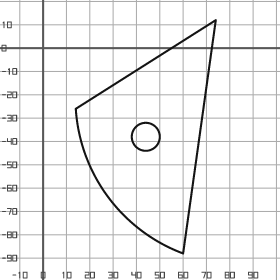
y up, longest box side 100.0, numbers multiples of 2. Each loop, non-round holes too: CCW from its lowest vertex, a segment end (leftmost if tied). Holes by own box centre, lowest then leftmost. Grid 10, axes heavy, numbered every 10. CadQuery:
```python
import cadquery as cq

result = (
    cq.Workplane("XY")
    .moveTo(60.0, -88.0)
    .lineTo(74.0, 12.0)
    .lineTo(14.0, -26.0)
    .threePointArc((28.0, -64.0), (60.0, -88.0))
    .close()
    .moveTo(44.0, -38.0)
    .circle(6.0)
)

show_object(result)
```